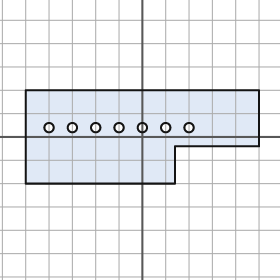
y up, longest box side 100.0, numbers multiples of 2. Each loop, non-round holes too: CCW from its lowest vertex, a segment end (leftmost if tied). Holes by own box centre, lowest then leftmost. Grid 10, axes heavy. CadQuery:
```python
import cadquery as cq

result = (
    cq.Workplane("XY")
    .moveTo(-50.0, -20.0)
    .lineTo(14.0, -20.0)
    .lineTo(14.0, -4.0)
    .lineTo(50.0, -4.0)
    .lineTo(50.0, 20.0)
    .lineTo(-50.0, 20.0)
    .close()
    .moveTo(-40.0, 4.0)
    .circle(2.0)
    .moveTo(-30.0, 4.0)
    .circle(2.0)
    .moveTo(-20.0, 4.0)
    .circle(2.0)
    .moveTo(-10.0, 4.0)
    .circle(2.0)
    .moveTo(0.0, 4.0)
    .circle(2.0)
    .moveTo(10.0, 4.0)
    .circle(2.0)
    .moveTo(20.0, 4.0)
    .circle(2.0)
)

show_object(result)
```